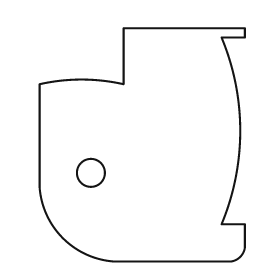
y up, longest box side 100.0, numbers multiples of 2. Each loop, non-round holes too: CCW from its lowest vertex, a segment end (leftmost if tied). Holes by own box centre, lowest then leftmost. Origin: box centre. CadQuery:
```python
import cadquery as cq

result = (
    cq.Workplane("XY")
    .moveTo(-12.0, -50.0)
    .lineTo(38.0, -50.0)
    .threePointArc((42.0, -48.0), (44.0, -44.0))
    .lineTo(44.0, -34.0)
    .lineTo(34.0, -34.0)
    .threePointArc((42.0, 6.0), (34.0, 46.0))
    .lineTo(44.0, 46.0)
    .lineTo(44.0, 50.0)
    .lineTo(-8.0, 50.0)
    .lineTo(-8.0, 26.0)
    .threePointArc((-26.0, 28.0), (-44.0, 26.0))
    .lineTo(-44.0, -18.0)
    .threePointArc((-34.0, -40.0), (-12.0, -50.0))
    .close()
    .moveTo(-22.0, -12.0)
    .circle(6.0)
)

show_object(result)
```